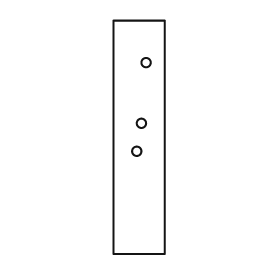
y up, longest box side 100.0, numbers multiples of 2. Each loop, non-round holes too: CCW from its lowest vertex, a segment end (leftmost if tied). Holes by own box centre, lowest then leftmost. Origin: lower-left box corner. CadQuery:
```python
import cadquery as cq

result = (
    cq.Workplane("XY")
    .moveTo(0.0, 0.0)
    .lineTo(22.0, 0.0)
    .lineTo(22.0, 100.0)
    .lineTo(0.0, 100.0)
    .close()
    .moveTo(10.0, 44.0)
    .circle(2.0)
    .moveTo(12.0, 56.0)
    .circle(2.0)
    .moveTo(14.0, 82.0)
    .circle(2.0)
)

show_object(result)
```